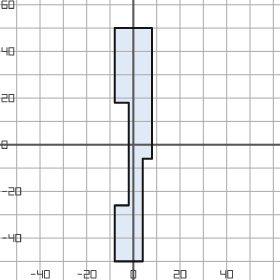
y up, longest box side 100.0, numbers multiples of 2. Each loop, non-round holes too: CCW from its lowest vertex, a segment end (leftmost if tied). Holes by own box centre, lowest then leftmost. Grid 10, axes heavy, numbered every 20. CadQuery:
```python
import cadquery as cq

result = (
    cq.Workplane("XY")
    .moveTo(-8.0, -50.0)
    .lineTo(4.0, -50.0)
    .lineTo(4.0, -6.0)
    .lineTo(8.0, -6.0)
    .lineTo(8.0, 50.0)
    .lineTo(-8.0, 50.0)
    .lineTo(-8.0, 18.0)
    .lineTo(-2.0, 18.0)
    .lineTo(-2.0, -26.0)
    .lineTo(-8.0, -26.0)
    .close()
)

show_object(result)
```